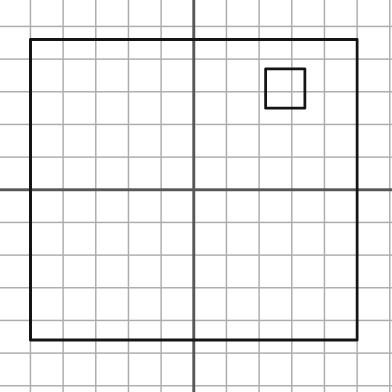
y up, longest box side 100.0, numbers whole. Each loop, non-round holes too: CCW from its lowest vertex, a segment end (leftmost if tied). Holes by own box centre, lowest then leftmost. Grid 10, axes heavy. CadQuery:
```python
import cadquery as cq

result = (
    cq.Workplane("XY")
    .moveTo(-50.0, -46.0)
    .lineTo(50.0, -46.0)
    .lineTo(50.0, 46.0)
    .lineTo(-50.0, 46.0)
    .close()
    .moveTo(22.0, 25.0)
    .lineTo(34.0, 25.0)
    .lineTo(34.0, 37.0)
    .lineTo(22.0, 37.0)
    .close()
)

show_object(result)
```